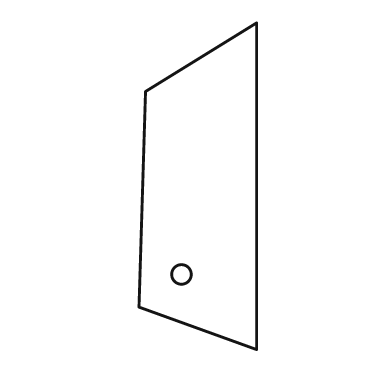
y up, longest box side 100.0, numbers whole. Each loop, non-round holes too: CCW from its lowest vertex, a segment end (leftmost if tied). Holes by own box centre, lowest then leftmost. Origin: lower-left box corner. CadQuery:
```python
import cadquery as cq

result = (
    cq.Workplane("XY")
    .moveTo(36.0, 0.0)
    .lineTo(36.0, 100.0)
    .lineTo(2.0, 79.0)
    .lineTo(0.0, 13.0)
    .close()
    .moveTo(13.0, 23.0)
    .circle(3.0)
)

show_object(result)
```